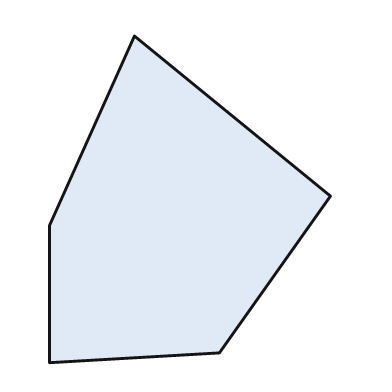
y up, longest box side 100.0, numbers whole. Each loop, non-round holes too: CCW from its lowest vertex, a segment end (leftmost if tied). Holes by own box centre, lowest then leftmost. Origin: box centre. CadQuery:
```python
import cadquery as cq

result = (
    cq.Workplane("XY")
    .moveTo(-43.0, -50.0)
    .lineTo(9.0, -47.0)
    .lineTo(43.0, 1.0)
    .lineTo(-17.0, 50.0)
    .lineTo(-43.0, -8.0)
    .close()
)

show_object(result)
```